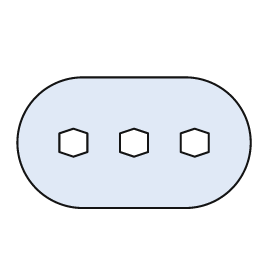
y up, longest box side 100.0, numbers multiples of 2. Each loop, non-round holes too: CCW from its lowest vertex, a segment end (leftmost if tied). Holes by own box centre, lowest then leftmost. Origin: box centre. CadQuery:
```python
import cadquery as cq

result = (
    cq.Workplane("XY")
    .moveTo(-22.0, -28.0)
    .lineTo(22.0, -28.0)
    .threePointArc((50.0, 0.0), (22.0, 28.0))
    .lineTo(-22.0, 28.0)
    .threePointArc((-50.0, 0.0), (-22.0, -28.0))
    .close()
    .moveTo(-26.0, -6.0)
    .lineTo(-20.0, -4.0)
    .lineTo(-20.0, 4.0)
    .lineTo(-26.0, 6.0)
    .lineTo(-32.0, 4.0)
    .lineTo(-32.0, -4.0)
    .close()
    .moveTo(0.0, -6.0)
    .lineTo(6.0, -4.0)
    .lineTo(6.0, 4.0)
    .lineTo(0.0, 6.0)
    .lineTo(-6.0, 4.0)
    .lineTo(-6.0, -4.0)
    .close()
    .moveTo(26.0, -6.0)
    .lineTo(32.0, -4.0)
    .lineTo(32.0, 4.0)
    .lineTo(26.0, 6.0)
    .lineTo(20.0, 4.0)
    .lineTo(20.0, -4.0)
    .close()
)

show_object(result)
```